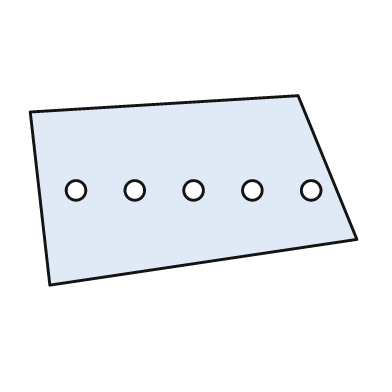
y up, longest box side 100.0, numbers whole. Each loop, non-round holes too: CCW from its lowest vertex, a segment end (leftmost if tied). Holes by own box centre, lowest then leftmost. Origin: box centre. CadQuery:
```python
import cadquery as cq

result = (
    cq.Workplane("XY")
    .moveTo(-44.0, -29.0)
    .lineTo(50.0, -15.0)
    .lineTo(32.0, 29.0)
    .lineTo(-50.0, 24.0)
    .close()
    .moveTo(-36.0, 0.0)
    .circle(3.0)
    .moveTo(-18.0, 0.0)
    .circle(3.0)
    .moveTo(0.0, 0.0)
    .circle(3.0)
    .moveTo(18.0, 0.0)
    .circle(3.0)
    .moveTo(36.0, 0.0)
    .circle(3.0)
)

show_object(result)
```